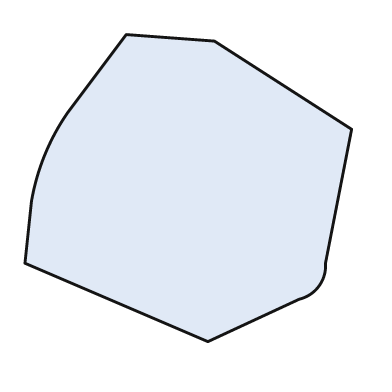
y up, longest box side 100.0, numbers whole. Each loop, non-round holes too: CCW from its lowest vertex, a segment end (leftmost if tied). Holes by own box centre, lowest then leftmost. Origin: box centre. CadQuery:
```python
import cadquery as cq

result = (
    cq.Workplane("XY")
    .moveTo(6.0, -47.0)
    .lineTo(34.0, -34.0)
    .threePointArc((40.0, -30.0), (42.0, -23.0))
    .lineTo(50.0, 18.0)
    .lineTo(8.0, 45.0)
    .lineTo(-19.0, 47.0)
    .lineTo(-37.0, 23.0)
    .threePointArc((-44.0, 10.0), (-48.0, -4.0))
    .lineTo(-50.0, -23.0)
    .close()
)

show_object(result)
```